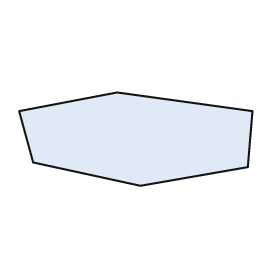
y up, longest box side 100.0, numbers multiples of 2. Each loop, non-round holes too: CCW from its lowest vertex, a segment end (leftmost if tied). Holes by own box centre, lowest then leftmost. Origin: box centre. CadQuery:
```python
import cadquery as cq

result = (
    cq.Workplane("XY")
    .moveTo(2.0, -20.0)
    .lineTo(48.0, -12.0)
    .lineTo(50.0, 12.0)
    .lineTo(-8.0, 20.0)
    .lineTo(-50.0, 12.0)
    .lineTo(-44.0, -10.0)
    .close()
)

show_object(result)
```